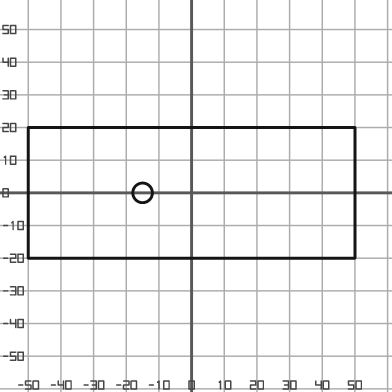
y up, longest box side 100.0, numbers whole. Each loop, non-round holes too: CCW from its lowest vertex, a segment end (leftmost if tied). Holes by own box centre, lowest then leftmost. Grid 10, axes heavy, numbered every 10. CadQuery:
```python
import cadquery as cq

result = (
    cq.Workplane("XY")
    .moveTo(-50.0, -20.0)
    .lineTo(50.0, -20.0)
    .lineTo(50.0, 20.0)
    .lineTo(-50.0, 20.0)
    .close()
    .moveTo(-15.0, 0.0)
    .circle(3.0)
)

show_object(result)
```